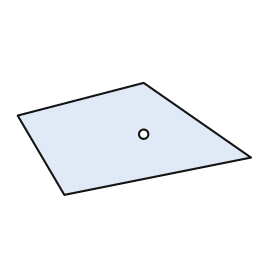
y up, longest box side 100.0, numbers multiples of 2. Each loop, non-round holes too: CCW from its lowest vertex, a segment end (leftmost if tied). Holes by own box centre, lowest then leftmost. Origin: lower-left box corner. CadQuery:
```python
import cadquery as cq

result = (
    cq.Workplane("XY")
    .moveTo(20.0, 0.0)
    .lineTo(100.0, 16.0)
    .lineTo(54.0, 48.0)
    .lineTo(0.0, 34.0)
    .close()
    .moveTo(54.0, 26.0)
    .circle(2.0)
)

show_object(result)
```